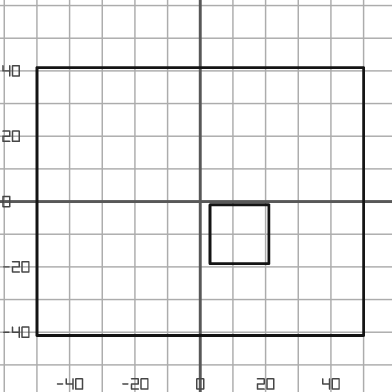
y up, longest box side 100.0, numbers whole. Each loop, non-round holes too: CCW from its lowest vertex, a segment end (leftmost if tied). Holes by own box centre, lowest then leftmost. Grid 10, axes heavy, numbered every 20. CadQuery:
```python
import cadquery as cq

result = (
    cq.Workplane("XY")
    .moveTo(-50.0, -41.0)
    .lineTo(50.0, -41.0)
    .lineTo(50.0, 41.0)
    .lineTo(-50.0, 41.0)
    .close()
    .moveTo(3.0, -19.0)
    .lineTo(21.0, -19.0)
    .lineTo(21.0, -1.0)
    .lineTo(3.0, -1.0)
    .close()
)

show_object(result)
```